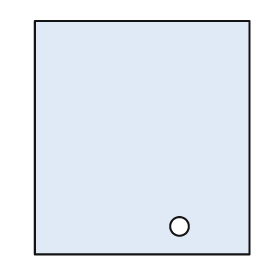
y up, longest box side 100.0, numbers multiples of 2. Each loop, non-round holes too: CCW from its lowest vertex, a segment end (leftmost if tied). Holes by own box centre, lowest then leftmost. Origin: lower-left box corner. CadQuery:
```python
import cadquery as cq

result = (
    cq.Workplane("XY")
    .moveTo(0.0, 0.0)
    .lineTo(92.0, 0.0)
    .lineTo(92.0, 100.0)
    .lineTo(0.0, 100.0)
    .close()
    .moveTo(62.0, 12.0)
    .circle(4.0)
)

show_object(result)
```